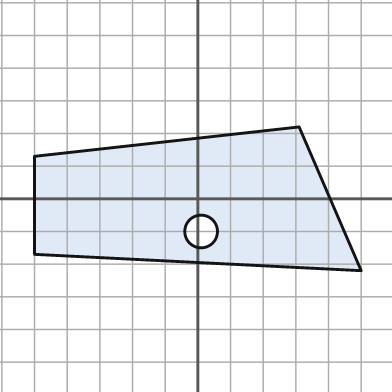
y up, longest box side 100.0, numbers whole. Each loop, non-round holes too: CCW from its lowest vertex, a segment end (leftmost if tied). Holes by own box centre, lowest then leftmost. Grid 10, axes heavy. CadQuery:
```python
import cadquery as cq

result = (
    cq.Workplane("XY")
    .moveTo(50.0, -22.0)
    .lineTo(31.0, 22.0)
    .lineTo(-50.0, 13.0)
    .lineTo(-50.0, -17.0)
    .close()
    .moveTo(1.0, -10.0)
    .circle(5.0)
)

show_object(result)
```